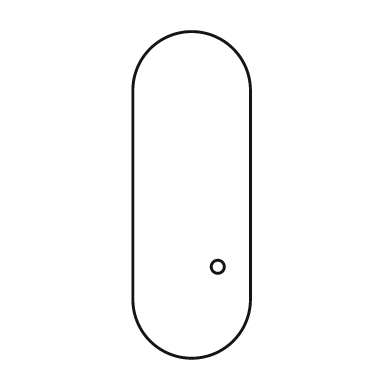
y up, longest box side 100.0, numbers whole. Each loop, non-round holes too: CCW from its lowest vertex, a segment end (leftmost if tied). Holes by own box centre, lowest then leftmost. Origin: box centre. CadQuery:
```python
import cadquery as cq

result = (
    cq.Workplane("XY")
    .moveTo(-18.0, -32.0)
    .threePointArc((0.0, -50.0), (18.0, -32.0))
    .lineTo(18.0, 32.0)
    .threePointArc((0.0, 50.0), (-18.0, 32.0))
    .close()
    .moveTo(8.0, -22.0)
    .circle(2.0)
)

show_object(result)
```